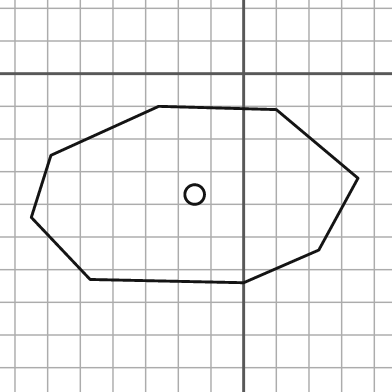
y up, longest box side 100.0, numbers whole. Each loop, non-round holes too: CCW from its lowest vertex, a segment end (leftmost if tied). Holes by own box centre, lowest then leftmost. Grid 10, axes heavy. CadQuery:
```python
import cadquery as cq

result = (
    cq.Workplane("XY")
    .moveTo(0.0, -64.0)
    .lineTo(23.0, -54.0)
    .lineTo(35.0, -32.0)
    .lineTo(10.0, -11.0)
    .lineTo(-26.0, -10.0)
    .lineTo(-59.0, -25.0)
    .lineTo(-65.0, -44.0)
    .lineTo(-47.0, -63.0)
    .close()
    .moveTo(-15.0, -37.0)
    .circle(3.0)
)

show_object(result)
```